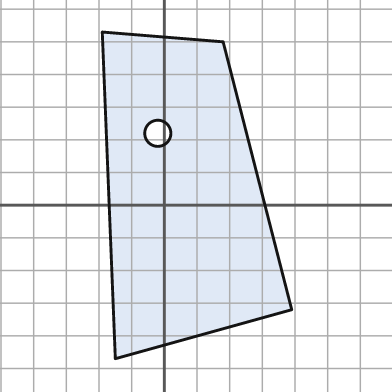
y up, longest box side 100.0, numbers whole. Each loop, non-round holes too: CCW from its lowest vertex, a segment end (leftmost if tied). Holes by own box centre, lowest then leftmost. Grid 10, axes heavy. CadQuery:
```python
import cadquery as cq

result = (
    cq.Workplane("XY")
    .moveTo(-15.0, -47.0)
    .lineTo(39.0, -32.0)
    .lineTo(18.0, 50.0)
    .lineTo(-19.0, 53.0)
    .close()
    .moveTo(-2.0, 22.0)
    .circle(4.0)
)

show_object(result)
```